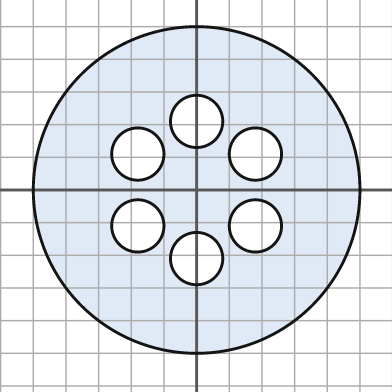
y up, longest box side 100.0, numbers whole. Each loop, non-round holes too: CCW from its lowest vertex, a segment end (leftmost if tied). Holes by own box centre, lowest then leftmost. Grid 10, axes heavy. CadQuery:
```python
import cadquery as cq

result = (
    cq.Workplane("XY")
    .moveTo(0.0, 0.0)
    .circle(50.0)
    .moveTo(0.0, -21.0)
    .circle(8.0)
    .moveTo(-18.0, -11.0)
    .circle(8.0)
    .moveTo(18.0, -11.0)
    .circle(8.0)
    .moveTo(-18.0, 11.0)
    .circle(8.0)
    .moveTo(18.0, 11.0)
    .circle(8.0)
    .moveTo(0.0, 21.0)
    .circle(8.0)
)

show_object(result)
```